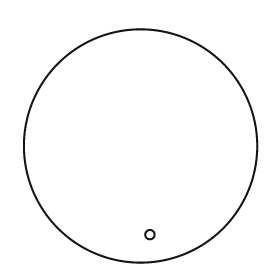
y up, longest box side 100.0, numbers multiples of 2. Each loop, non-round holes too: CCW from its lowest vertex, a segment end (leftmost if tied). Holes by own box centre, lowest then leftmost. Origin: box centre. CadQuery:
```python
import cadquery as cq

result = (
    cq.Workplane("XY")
    .moveTo(0.0, 0.0)
    .circle(50.0)
    .moveTo(4.0, -38.0)
    .circle(2.0)
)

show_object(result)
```